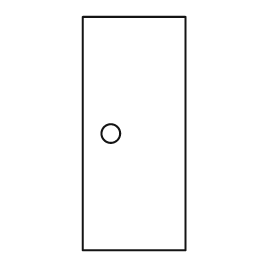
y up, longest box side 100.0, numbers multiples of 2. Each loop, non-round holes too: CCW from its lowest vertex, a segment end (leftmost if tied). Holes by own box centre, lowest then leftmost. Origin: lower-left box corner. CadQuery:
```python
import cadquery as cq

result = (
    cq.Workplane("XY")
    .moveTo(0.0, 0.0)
    .lineTo(44.0, 0.0)
    .lineTo(44.0, 100.0)
    .lineTo(0.0, 100.0)
    .close()
    .moveTo(12.0, 50.0)
    .circle(4.0)
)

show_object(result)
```